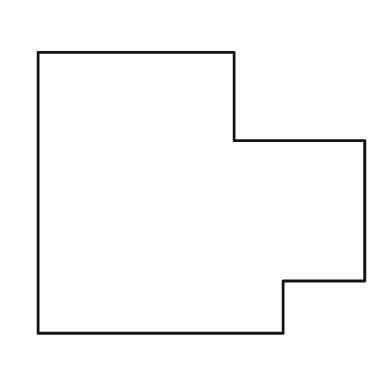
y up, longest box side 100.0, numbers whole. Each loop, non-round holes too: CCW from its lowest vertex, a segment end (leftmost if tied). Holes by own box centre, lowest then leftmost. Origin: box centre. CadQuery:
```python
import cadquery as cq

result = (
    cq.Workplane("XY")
    .moveTo(-50.0, -43.0)
    .lineTo(25.0, -43.0)
    .lineTo(25.0, -27.0)
    .lineTo(50.0, -27.0)
    .lineTo(50.0, 16.0)
    .lineTo(10.0, 16.0)
    .lineTo(10.0, 43.0)
    .lineTo(-50.0, 43.0)
    .close()
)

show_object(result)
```